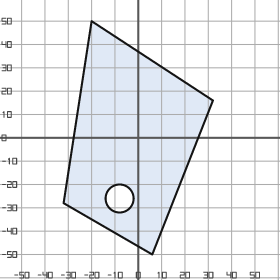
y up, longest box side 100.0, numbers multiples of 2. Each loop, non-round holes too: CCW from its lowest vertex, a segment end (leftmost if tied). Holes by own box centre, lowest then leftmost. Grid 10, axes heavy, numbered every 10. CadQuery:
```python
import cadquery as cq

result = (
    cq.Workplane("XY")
    .moveTo(6.0, -50.0)
    .lineTo(32.0, 16.0)
    .lineTo(-20.0, 50.0)
    .lineTo(-32.0, -28.0)
    .close()
    .moveTo(-8.0, -26.0)
    .circle(6.0)
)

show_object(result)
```